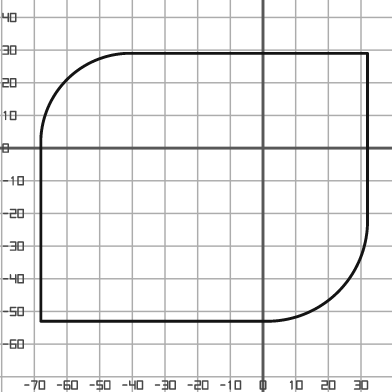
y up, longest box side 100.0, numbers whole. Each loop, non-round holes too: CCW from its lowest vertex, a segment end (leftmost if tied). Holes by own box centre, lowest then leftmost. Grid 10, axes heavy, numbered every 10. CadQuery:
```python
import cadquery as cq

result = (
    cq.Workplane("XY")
    .moveTo(-68.0, -53.0)
    .lineTo(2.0, -53.0)
    .threePointArc((23.0, -44.0), (32.0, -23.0))
    .lineTo(32.0, 29.0)
    .lineTo(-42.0, 29.0)
    .threePointArc((-60.0, 21.0), (-68.0, 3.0))
    .close()
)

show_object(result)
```